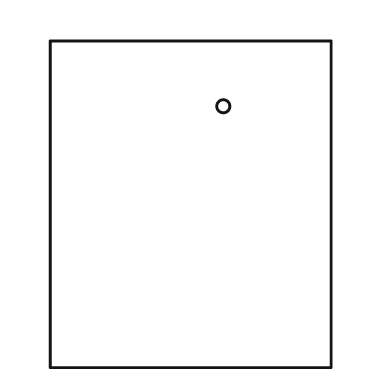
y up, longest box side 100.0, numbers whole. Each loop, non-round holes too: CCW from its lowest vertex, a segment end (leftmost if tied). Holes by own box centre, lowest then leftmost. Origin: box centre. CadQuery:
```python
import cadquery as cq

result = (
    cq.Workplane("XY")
    .moveTo(-43.0, -50.0)
    .lineTo(43.0, -50.0)
    .lineTo(43.0, 50.0)
    .lineTo(-43.0, 50.0)
    .close()
    .moveTo(10.0, 30.0)
    .circle(2.0)
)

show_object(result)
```